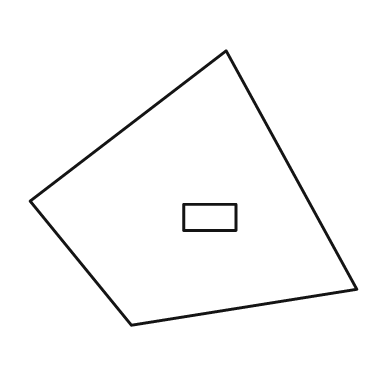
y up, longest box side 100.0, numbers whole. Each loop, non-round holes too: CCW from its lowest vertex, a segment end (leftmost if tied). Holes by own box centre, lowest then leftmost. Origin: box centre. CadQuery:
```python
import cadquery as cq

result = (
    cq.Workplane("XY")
    .moveTo(-19.0, -42.0)
    .lineTo(50.0, -31.0)
    .lineTo(10.0, 42.0)
    .lineTo(-50.0, -4.0)
    .close()
    .moveTo(-3.0, -13.0)
    .lineTo(13.0, -13.0)
    .lineTo(13.0, -5.0)
    .lineTo(-3.0, -5.0)
    .close()
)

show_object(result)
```